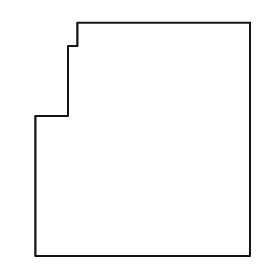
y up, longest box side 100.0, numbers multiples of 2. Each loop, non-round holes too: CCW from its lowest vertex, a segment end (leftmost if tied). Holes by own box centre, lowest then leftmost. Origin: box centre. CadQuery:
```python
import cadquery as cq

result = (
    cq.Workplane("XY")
    .moveTo(-46.0, -50.0)
    .lineTo(46.0, -50.0)
    .lineTo(46.0, 50.0)
    .lineTo(-28.0, 50.0)
    .lineTo(-28.0, 40.0)
    .lineTo(-32.0, 40.0)
    .lineTo(-32.0, 10.0)
    .lineTo(-46.0, 10.0)
    .close()
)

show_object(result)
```